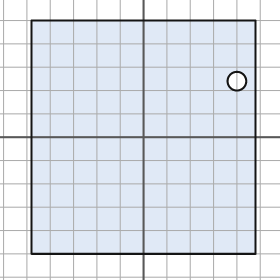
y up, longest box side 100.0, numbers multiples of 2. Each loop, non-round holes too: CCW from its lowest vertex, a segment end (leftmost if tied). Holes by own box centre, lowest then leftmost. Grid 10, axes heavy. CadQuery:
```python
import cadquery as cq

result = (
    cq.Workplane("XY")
    .moveTo(-48.0, -50.0)
    .lineTo(48.0, -50.0)
    .lineTo(48.0, 50.0)
    .lineTo(-48.0, 50.0)
    .close()
    .moveTo(40.0, 24.0)
    .circle(4.0)
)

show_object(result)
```